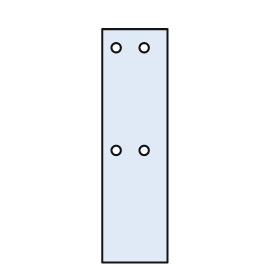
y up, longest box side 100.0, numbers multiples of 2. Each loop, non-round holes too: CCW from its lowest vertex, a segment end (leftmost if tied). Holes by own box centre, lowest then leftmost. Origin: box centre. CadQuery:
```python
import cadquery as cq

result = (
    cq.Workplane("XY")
    .moveTo(-14.0, -50.0)
    .lineTo(14.0, -50.0)
    .lineTo(14.0, 50.0)
    .lineTo(-14.0, 50.0)
    .close()
    .moveTo(-8.0, -2.0)
    .circle(2.0)
    .moveTo(4.0, -2.0)
    .circle(2.0)
    .moveTo(-8.0, 42.0)
    .circle(2.0)
    .moveTo(4.0, 42.0)
    .circle(2.0)
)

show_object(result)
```